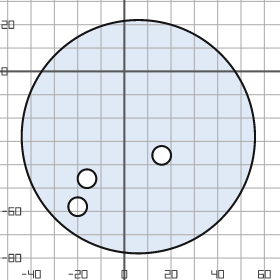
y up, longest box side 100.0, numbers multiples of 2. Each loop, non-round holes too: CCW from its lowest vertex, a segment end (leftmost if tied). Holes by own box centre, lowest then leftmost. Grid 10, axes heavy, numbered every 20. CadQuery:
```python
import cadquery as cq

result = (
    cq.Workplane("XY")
    .moveTo(6.0, -28.0)
    .circle(50.0)
    .moveTo(-20.0, -58.0)
    .circle(4.0)
    .moveTo(-16.0, -46.0)
    .circle(4.0)
    .moveTo(16.0, -36.0)
    .circle(4.0)
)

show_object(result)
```